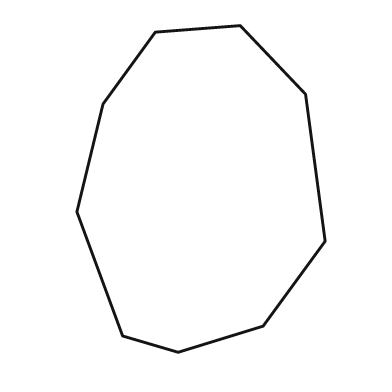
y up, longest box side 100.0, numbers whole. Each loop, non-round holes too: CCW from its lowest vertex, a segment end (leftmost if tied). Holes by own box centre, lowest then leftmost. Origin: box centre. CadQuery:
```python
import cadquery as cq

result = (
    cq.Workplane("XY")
    .moveTo(-7.0, -50.0)
    .lineTo(19.0, -42.0)
    .lineTo(38.0, -16.0)
    .lineTo(32.0, 29.0)
    .lineTo(12.0, 50.0)
    .lineTo(-14.0, 48.0)
    .lineTo(-30.0, 26.0)
    .lineTo(-38.0, -7.0)
    .lineTo(-24.0, -45.0)
    .close()
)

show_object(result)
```